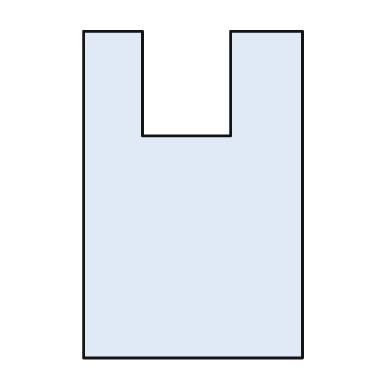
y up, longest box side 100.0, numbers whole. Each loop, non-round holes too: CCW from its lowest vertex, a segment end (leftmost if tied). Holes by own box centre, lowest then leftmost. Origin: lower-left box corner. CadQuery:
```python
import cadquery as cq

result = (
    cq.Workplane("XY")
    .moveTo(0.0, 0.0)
    .lineTo(67.0, 0.0)
    .lineTo(67.0, 100.0)
    .lineTo(45.0, 100.0)
    .lineTo(45.0, 68.0)
    .lineTo(18.0, 68.0)
    .lineTo(18.0, 100.0)
    .lineTo(0.0, 100.0)
    .close()
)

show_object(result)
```